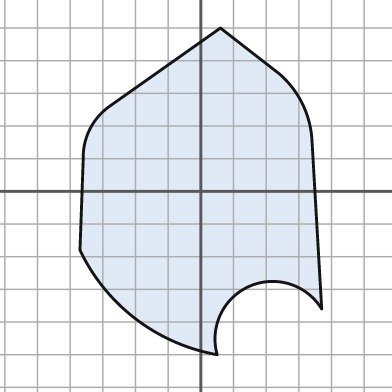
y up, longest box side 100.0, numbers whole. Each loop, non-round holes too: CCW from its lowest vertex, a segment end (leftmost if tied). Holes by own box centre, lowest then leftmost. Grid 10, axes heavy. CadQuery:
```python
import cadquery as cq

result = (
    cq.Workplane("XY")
    .moveTo(5.0, -50.0)
    .threePointArc((15.0, -29.0), (37.0, -36.0))
    .lineTo(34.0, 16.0)
    .threePointArc((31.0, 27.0), (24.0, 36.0))
    .lineTo(6.0, 50.0)
    .lineTo(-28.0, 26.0)
    .threePointArc((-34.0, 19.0), (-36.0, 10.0))
    .lineTo(-37.0, -18.0)
    .threePointArc((-20.0, -39.0), (5.0, -50.0))
    .close()
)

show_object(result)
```